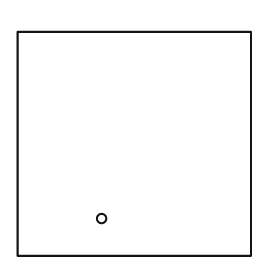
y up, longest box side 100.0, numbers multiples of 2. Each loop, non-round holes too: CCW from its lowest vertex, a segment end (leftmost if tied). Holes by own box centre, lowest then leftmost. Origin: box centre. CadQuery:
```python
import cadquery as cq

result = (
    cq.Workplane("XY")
    .moveTo(-50.0, -48.0)
    .lineTo(50.0, -48.0)
    .lineTo(50.0, 48.0)
    .lineTo(-50.0, 48.0)
    .close()
    .moveTo(-14.0, -32.0)
    .circle(2.0)
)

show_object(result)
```